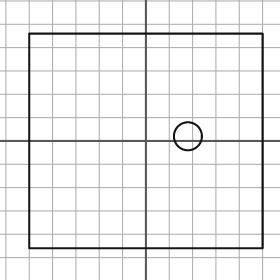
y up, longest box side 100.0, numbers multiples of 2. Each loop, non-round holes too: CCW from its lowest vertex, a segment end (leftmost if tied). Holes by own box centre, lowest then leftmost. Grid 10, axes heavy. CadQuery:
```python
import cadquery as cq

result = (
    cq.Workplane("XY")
    .moveTo(-50.0, -46.0)
    .lineTo(50.0, -46.0)
    .lineTo(50.0, 46.0)
    .lineTo(-50.0, 46.0)
    .close()
    .moveTo(18.0, 2.0)
    .circle(6.0)
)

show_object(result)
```